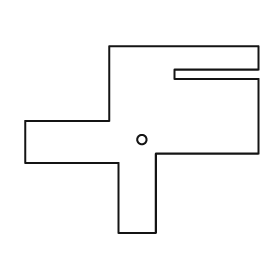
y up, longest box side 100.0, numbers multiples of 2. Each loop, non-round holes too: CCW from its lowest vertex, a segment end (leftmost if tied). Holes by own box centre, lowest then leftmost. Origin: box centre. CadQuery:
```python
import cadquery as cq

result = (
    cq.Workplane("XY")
    .moveTo(-10.0, -40.0)
    .lineTo(6.0, -40.0)
    .lineTo(6.0, -6.0)
    .lineTo(50.0, -6.0)
    .lineTo(50.0, 26.0)
    .lineTo(14.0, 26.0)
    .lineTo(14.0, 30.0)
    .lineTo(50.0, 30.0)
    .lineTo(50.0, 40.0)
    .lineTo(-14.0, 40.0)
    .lineTo(-14.0, 8.0)
    .lineTo(-50.0, 8.0)
    .lineTo(-50.0, -10.0)
    .lineTo(-10.0, -10.0)
    .close()
    .moveTo(0.0, 0.0)
    .circle(2.0)
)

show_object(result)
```